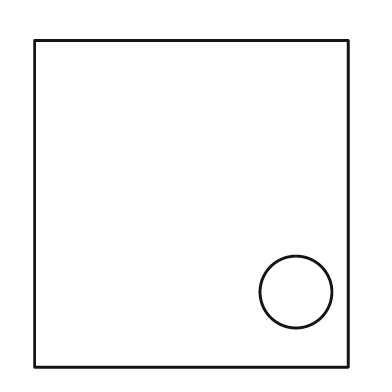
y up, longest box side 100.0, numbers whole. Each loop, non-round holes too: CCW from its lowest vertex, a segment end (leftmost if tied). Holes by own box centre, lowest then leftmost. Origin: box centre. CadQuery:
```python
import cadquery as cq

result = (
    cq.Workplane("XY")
    .moveTo(-48.0, -50.0)
    .lineTo(48.0, -50.0)
    .lineTo(48.0, 50.0)
    .lineTo(-48.0, 50.0)
    .close()
    .moveTo(32.0, -27.0)
    .circle(11.0)
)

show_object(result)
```